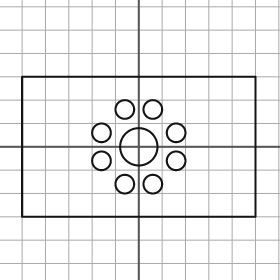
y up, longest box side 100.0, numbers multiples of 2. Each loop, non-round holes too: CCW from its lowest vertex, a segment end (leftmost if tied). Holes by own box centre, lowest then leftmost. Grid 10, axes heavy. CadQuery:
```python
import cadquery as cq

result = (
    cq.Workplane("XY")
    .moveTo(-50.0, -30.0)
    .lineTo(50.0, -30.0)
    .lineTo(50.0, 30.0)
    .lineTo(-50.0, 30.0)
    .close()
    .moveTo(-6.0, -16.0)
    .circle(4.0)
    .moveTo(6.0, -16.0)
    .circle(4.0)
    .moveTo(-16.0, -6.0)
    .circle(4.0)
    .moveTo(16.0, -6.0)
    .circle(4.0)
    .moveTo(0.0, 0.0)
    .circle(8.0)
    .moveTo(-16.0, 6.0)
    .circle(4.0)
    .moveTo(16.0, 6.0)
    .circle(4.0)
    .moveTo(-6.0, 16.0)
    .circle(4.0)
    .moveTo(6.0, 16.0)
    .circle(4.0)
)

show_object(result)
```